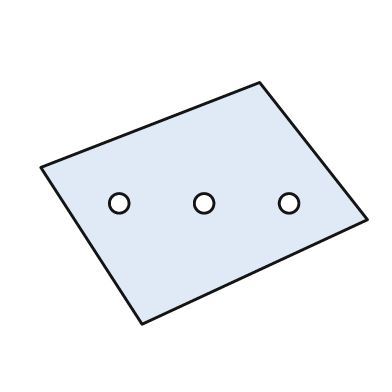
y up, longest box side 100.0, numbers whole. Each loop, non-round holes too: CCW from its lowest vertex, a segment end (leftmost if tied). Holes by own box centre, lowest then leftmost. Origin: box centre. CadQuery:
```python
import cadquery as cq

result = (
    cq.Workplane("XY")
    .moveTo(-19.0, -37.0)
    .lineTo(50.0, -5.0)
    .lineTo(17.0, 37.0)
    .lineTo(-50.0, 11.0)
    .close()
    .moveTo(-26.0, 0.0)
    .circle(3.0)
    .moveTo(0.0, 0.0)
    .circle(3.0)
    .moveTo(26.0, 0.0)
    .circle(3.0)
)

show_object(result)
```